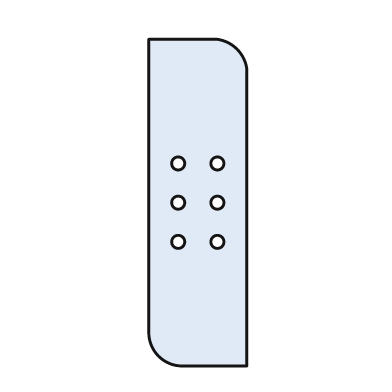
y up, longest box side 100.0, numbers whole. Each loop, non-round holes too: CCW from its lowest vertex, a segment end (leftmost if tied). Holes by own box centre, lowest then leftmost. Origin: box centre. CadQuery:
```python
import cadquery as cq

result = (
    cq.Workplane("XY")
    .moveTo(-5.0, -50.0)
    .lineTo(15.0, -50.0)
    .lineTo(15.0, 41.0)
    .threePointArc((12.0, 47.0), (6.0, 50.0))
    .lineTo(-15.0, 50.0)
    .lineTo(-15.0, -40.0)
    .threePointArc((-12.0, -47.0), (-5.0, -50.0))
    .close()
    .moveTo(-6.0, -12.0)
    .circle(2.0)
    .moveTo(6.0, -12.0)
    .circle(2.0)
    .moveTo(-6.0, 0.0)
    .circle(2.0)
    .moveTo(6.0, 0.0)
    .circle(2.0)
    .moveTo(-6.0, 12.0)
    .circle(2.0)
    .moveTo(6.0, 12.0)
    .circle(2.0)
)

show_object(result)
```